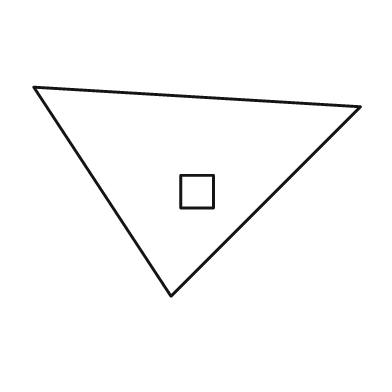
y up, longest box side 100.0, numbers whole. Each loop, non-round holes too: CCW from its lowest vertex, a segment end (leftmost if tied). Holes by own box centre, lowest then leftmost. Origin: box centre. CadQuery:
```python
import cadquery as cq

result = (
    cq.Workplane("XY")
    .moveTo(-8.0, -32.0)
    .lineTo(50.0, 26.0)
    .lineTo(-50.0, 32.0)
    .close()
    .moveTo(-5.0, -5.0)
    .lineTo(5.0, -5.0)
    .lineTo(5.0, 5.0)
    .lineTo(-5.0, 5.0)
    .close()
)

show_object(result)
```